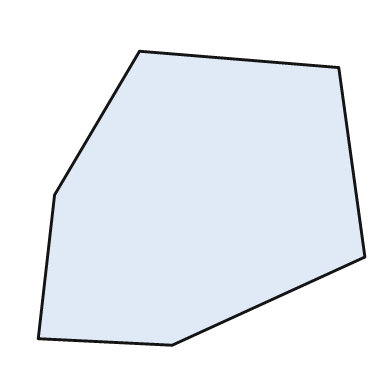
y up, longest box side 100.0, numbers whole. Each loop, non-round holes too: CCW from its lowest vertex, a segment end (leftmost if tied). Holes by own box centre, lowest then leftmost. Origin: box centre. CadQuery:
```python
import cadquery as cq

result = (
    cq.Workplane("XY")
    .moveTo(-9.0, -45.0)
    .lineTo(50.0, -18.0)
    .lineTo(42.0, 40.0)
    .lineTo(-19.0, 45.0)
    .lineTo(-45.0, 1.0)
    .lineTo(-50.0, -43.0)
    .close()
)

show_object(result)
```